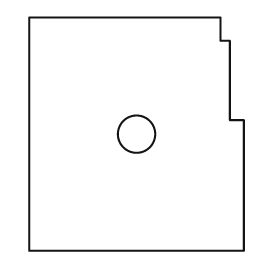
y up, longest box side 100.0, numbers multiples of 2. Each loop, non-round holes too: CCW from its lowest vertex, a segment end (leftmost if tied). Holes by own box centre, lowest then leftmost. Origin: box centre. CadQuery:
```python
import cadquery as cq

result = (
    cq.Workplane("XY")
    .moveTo(-46.0, -50.0)
    .lineTo(46.0, -50.0)
    .lineTo(46.0, 6.0)
    .lineTo(40.0, 6.0)
    .lineTo(40.0, 40.0)
    .lineTo(36.0, 40.0)
    .lineTo(36.0, 50.0)
    .lineTo(-46.0, 50.0)
    .close()
    .moveTo(0.0, 0.0)
    .circle(8.0)
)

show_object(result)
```